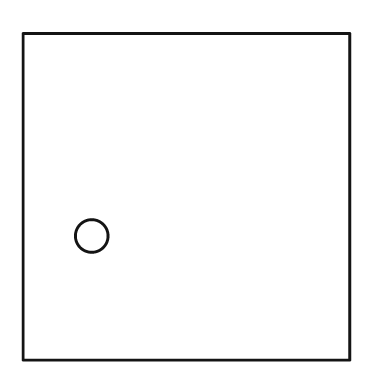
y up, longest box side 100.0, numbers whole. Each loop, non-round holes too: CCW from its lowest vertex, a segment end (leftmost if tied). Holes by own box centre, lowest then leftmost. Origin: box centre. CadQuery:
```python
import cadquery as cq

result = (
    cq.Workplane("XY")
    .moveTo(-50.0, -50.0)
    .lineTo(50.0, -50.0)
    .lineTo(50.0, 50.0)
    .lineTo(-50.0, 50.0)
    .close()
    .moveTo(-29.0, -12.0)
    .circle(5.0)
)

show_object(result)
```